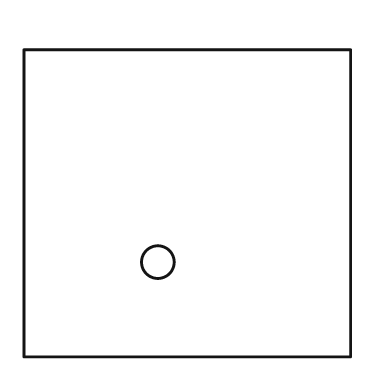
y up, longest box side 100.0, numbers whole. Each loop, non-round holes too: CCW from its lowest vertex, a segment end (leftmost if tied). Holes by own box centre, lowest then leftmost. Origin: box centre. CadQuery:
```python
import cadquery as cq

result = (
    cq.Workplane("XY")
    .moveTo(-50.0, -47.0)
    .lineTo(50.0, -47.0)
    .lineTo(50.0, 47.0)
    .lineTo(-50.0, 47.0)
    .close()
    .moveTo(-9.0, -18.0)
    .circle(5.0)
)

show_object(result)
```